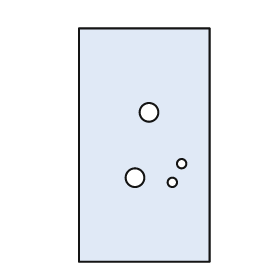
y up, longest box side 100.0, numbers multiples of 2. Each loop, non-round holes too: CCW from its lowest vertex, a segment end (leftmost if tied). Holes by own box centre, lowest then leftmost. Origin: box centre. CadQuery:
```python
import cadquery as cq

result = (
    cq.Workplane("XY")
    .moveTo(-28.0, -50.0)
    .lineTo(28.0, -50.0)
    .lineTo(28.0, 50.0)
    .lineTo(-28.0, 50.0)
    .close()
    .moveTo(12.0, -16.0)
    .circle(2.0)
    .moveTo(-4.0, -14.0)
    .circle(4.0)
    .moveTo(16.0, -8.0)
    .circle(2.0)
    .moveTo(2.0, 14.0)
    .circle(4.0)
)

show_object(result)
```